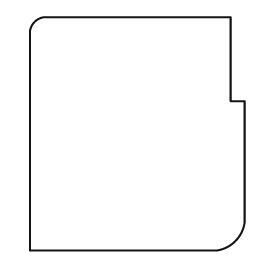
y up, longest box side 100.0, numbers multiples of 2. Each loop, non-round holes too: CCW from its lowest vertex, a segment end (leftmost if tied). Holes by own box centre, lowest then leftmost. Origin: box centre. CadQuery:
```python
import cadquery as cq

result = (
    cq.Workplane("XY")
    .moveTo(-46.0, -50.0)
    .lineTo(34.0, -50.0)
    .threePointArc((42.0, -46.0), (46.0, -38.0))
    .lineTo(46.0, 14.0)
    .lineTo(40.0, 14.0)
    .lineTo(40.0, 50.0)
    .lineTo(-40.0, 50.0)
    .threePointArc((-44.0, 48.0), (-46.0, 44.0))
    .close()
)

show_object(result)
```